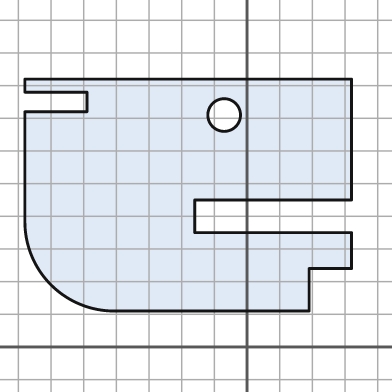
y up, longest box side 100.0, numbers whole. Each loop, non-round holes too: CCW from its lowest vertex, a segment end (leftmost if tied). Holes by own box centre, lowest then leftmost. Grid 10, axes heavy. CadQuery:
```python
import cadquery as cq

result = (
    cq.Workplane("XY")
    .moveTo(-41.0, 11.0)
    .lineTo(19.0, 11.0)
    .lineTo(19.0, 24.0)
    .lineTo(32.0, 24.0)
    .lineTo(32.0, 35.0)
    .lineTo(-16.0, 35.0)
    .lineTo(-16.0, 45.0)
    .lineTo(32.0, 45.0)
    .lineTo(32.0, 82.0)
    .lineTo(-68.0, 82.0)
    .lineTo(-68.0, 78.0)
    .lineTo(-49.0, 78.0)
    .lineTo(-49.0, 72.0)
    .lineTo(-68.0, 72.0)
    .lineTo(-68.0, 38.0)
    .threePointArc((-60.0, 19.0), (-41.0, 11.0))
    .close()
    .moveTo(-7.0, 71.0)
    .circle(5.0)
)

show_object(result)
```